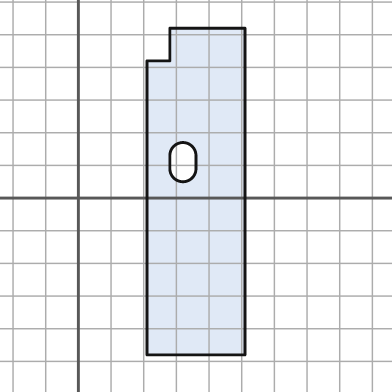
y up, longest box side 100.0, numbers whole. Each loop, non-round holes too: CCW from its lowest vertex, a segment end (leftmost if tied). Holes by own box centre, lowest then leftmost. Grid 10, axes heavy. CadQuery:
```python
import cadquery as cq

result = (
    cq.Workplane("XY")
    .moveTo(21.0, -48.0)
    .lineTo(51.0, -48.0)
    .lineTo(51.0, 52.0)
    .lineTo(28.0, 52.0)
    .lineTo(28.0, 42.0)
    .lineTo(21.0, 42.0)
    .close()
    .moveTo(28.0, 9.0)
    .threePointArc((32.0, 5.0), (36.0, 9.0))
    .lineTo(36.0, 13.0)
    .threePointArc((32.0, 17.0), (28.0, 13.0))
    .close()
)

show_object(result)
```